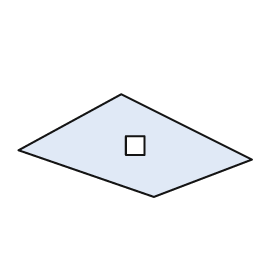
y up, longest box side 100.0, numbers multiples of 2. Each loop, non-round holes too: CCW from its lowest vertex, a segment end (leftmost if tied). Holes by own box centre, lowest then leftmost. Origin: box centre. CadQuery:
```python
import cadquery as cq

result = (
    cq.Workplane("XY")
    .moveTo(8.0, -22.0)
    .lineTo(50.0, -6.0)
    .lineTo(-6.0, 22.0)
    .lineTo(-50.0, -2.0)
    .close()
    .moveTo(-4.0, -4.0)
    .lineTo(4.0, -4.0)
    .lineTo(4.0, 4.0)
    .lineTo(-4.0, 4.0)
    .close()
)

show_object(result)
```